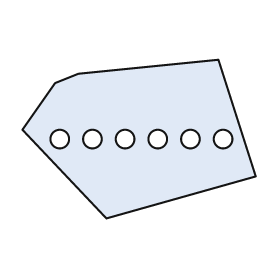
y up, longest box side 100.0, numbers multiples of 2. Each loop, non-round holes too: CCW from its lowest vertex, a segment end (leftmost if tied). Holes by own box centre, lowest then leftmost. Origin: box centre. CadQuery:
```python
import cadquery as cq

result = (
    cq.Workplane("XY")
    .moveTo(-14.0, -34.0)
    .lineTo(50.0, -16.0)
    .lineTo(34.0, 34.0)
    .lineTo(-26.0, 28.0)
    .lineTo(-36.0, 24.0)
    .lineTo(-50.0, 4.0)
    .close()
    .moveTo(-34.0, 0.0)
    .circle(4.0)
    .moveTo(-20.0, 0.0)
    .circle(4.0)
    .moveTo(-6.0, 0.0)
    .circle(4.0)
    .moveTo(8.0, 0.0)
    .circle(4.0)
    .moveTo(22.0, 0.0)
    .circle(4.0)
    .moveTo(36.0, 0.0)
    .circle(4.0)
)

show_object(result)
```